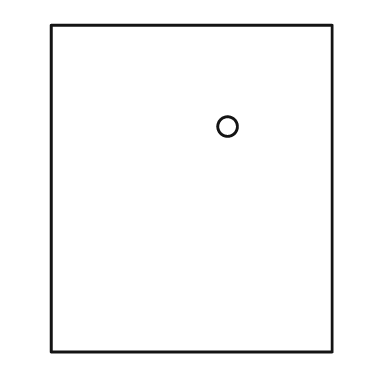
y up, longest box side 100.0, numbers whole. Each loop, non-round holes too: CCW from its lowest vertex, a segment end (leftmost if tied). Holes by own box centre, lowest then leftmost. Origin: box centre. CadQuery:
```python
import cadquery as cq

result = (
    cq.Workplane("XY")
    .moveTo(-43.0, -50.0)
    .lineTo(43.0, -50.0)
    .lineTo(43.0, 50.0)
    .lineTo(-43.0, 50.0)
    .close()
    .moveTo(11.0, 19.0)
    .circle(3.0)
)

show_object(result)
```